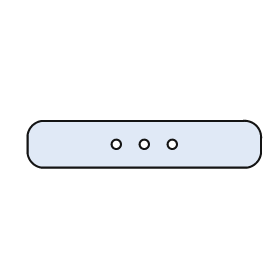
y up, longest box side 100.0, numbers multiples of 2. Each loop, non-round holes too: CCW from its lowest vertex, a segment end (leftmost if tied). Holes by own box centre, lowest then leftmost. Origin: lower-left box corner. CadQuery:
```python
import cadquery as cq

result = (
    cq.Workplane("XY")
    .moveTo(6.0, 0.0)
    .lineTo(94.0, 0.0)
    .threePointArc((98.0, 2.0), (100.0, 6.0))
    .lineTo(100.0, 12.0)
    .threePointArc((98.0, 18.0), (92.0, 20.0))
    .lineTo(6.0, 20.0)
    .threePointArc((2.0, 18.0), (0.0, 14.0))
    .lineTo(0.0, 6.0)
    .threePointArc((2.0, 2.0), (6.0, 0.0))
    .close()
    .moveTo(38.0, 10.0)
    .circle(2.0)
    .moveTo(50.0, 10.0)
    .circle(2.0)
    .moveTo(62.0, 10.0)
    .circle(2.0)
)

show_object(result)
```